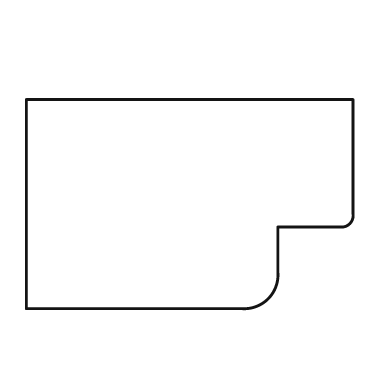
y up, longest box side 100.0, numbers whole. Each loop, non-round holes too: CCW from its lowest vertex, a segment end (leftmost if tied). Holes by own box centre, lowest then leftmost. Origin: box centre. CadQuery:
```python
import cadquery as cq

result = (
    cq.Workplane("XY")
    .moveTo(-50.0, -32.0)
    .lineTo(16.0, -32.0)
    .threePointArc((24.0, -29.0), (27.0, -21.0))
    .lineTo(27.0, -7.0)
    .lineTo(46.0, -7.0)
    .threePointArc((49.0, -6.0), (50.0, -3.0))
    .lineTo(50.0, 32.0)
    .lineTo(-50.0, 32.0)
    .close()
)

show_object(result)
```